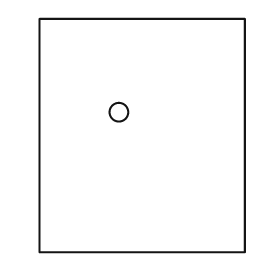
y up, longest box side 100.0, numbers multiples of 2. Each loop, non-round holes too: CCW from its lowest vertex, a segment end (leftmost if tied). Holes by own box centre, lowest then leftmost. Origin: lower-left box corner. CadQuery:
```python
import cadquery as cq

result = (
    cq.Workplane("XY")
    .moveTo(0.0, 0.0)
    .lineTo(88.0, 0.0)
    .lineTo(88.0, 100.0)
    .lineTo(0.0, 100.0)
    .close()
    .moveTo(34.0, 60.0)
    .circle(4.0)
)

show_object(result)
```